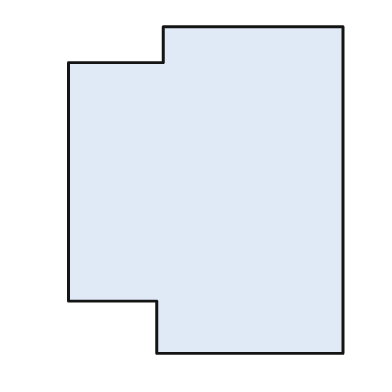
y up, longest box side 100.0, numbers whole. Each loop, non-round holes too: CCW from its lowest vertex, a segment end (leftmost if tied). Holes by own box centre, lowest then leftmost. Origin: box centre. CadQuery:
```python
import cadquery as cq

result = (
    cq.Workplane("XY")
    .moveTo(-15.0, -50.0)
    .lineTo(42.0, -50.0)
    .lineTo(42.0, 50.0)
    .lineTo(-13.0, 50.0)
    .lineTo(-13.0, 39.0)
    .lineTo(-42.0, 39.0)
    .lineTo(-42.0, -34.0)
    .lineTo(-15.0, -34.0)
    .close()
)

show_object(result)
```